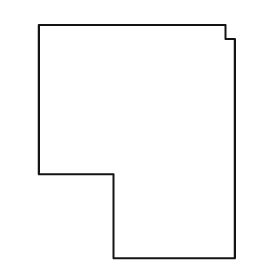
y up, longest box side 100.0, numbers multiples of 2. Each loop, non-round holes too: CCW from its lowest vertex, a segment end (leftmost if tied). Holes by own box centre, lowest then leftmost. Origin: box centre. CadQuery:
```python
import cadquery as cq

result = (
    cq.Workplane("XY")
    .moveTo(-10.0, -50.0)
    .lineTo(42.0, -50.0)
    .lineTo(42.0, 44.0)
    .lineTo(38.0, 44.0)
    .lineTo(38.0, 50.0)
    .lineTo(-42.0, 50.0)
    .lineTo(-42.0, -14.0)
    .lineTo(-10.0, -14.0)
    .close()
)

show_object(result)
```